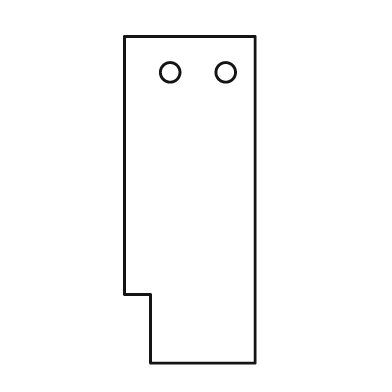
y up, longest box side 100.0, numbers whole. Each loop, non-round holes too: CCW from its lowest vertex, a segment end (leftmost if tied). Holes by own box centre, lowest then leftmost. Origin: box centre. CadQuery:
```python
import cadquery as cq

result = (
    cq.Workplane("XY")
    .moveTo(-12.0, -50.0)
    .lineTo(20.0, -50.0)
    .lineTo(20.0, 50.0)
    .lineTo(-20.0, 50.0)
    .lineTo(-20.0, -29.0)
    .lineTo(-12.0, -29.0)
    .close()
    .moveTo(-6.0, 39.0)
    .circle(3.0)
    .moveTo(11.0, 39.0)
    .circle(3.0)
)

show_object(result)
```